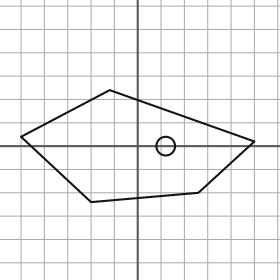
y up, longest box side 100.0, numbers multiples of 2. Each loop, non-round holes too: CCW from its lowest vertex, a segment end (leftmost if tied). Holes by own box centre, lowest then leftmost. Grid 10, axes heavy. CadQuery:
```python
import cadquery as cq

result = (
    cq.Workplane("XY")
    .moveTo(-20.0, -24.0)
    .lineTo(26.0, -20.0)
    .lineTo(50.0, 2.0)
    .lineTo(-12.0, 24.0)
    .lineTo(-50.0, 4.0)
    .close()
    .moveTo(12.0, 0.0)
    .circle(4.0)
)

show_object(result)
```